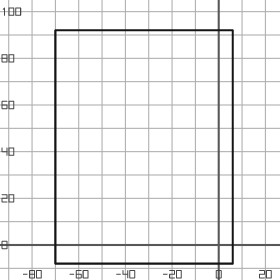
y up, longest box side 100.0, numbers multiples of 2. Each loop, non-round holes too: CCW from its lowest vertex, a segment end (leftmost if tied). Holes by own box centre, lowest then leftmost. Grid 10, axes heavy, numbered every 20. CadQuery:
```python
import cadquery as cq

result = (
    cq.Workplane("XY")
    .moveTo(-70.0, -8.0)
    .lineTo(6.0, -8.0)
    .lineTo(6.0, 92.0)
    .lineTo(-70.0, 92.0)
    .close()
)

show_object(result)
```